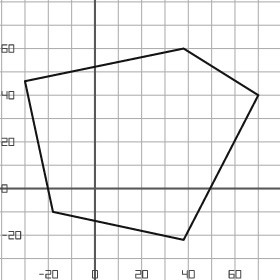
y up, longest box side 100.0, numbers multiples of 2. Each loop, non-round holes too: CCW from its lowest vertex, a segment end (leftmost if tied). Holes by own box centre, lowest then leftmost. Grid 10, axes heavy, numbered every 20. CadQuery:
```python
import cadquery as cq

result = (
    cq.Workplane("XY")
    .moveTo(38.0, -22.0)
    .lineTo(70.0, 40.0)
    .lineTo(38.0, 60.0)
    .lineTo(-30.0, 46.0)
    .lineTo(-18.0, -10.0)
    .close()
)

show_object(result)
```